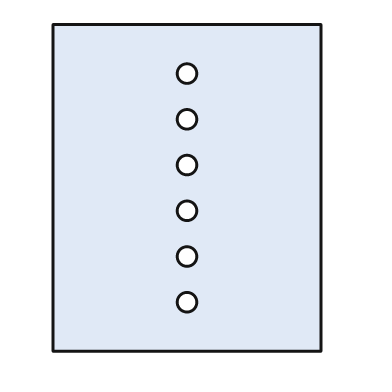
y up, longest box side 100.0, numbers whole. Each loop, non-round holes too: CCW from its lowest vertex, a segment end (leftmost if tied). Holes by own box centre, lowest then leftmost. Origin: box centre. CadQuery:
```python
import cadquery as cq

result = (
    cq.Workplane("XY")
    .moveTo(-41.0, -50.0)
    .lineTo(41.0, -50.0)
    .lineTo(41.0, 50.0)
    .lineTo(-41.0, 50.0)
    .close()
    .moveTo(0.0, -35.0)
    .circle(3.0)
    .moveTo(0.0, -21.0)
    .circle(3.0)
    .moveTo(0.0, -7.0)
    .circle(3.0)
    .moveTo(0.0, 7.0)
    .circle(3.0)
    .moveTo(0.0, 21.0)
    .circle(3.0)
    .moveTo(0.0, 35.0)
    .circle(3.0)
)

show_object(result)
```